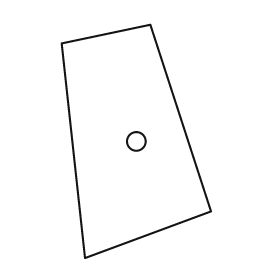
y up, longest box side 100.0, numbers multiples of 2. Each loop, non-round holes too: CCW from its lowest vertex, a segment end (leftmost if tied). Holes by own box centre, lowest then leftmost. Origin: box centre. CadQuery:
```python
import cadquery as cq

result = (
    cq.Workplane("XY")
    .moveTo(-22.0, -50.0)
    .lineTo(32.0, -30.0)
    .lineTo(6.0, 50.0)
    .lineTo(-32.0, 42.0)
    .close()
    .moveTo(0.0, 0.0)
    .circle(4.0)
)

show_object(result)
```